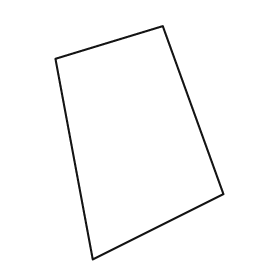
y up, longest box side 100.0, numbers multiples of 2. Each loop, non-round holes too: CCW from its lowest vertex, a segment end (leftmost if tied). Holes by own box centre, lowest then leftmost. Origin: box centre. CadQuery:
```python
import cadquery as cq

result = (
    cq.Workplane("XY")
    .moveTo(-20.0, -50.0)
    .lineTo(36.0, -22.0)
    .lineTo(10.0, 50.0)
    .lineTo(-36.0, 36.0)
    .close()
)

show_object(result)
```